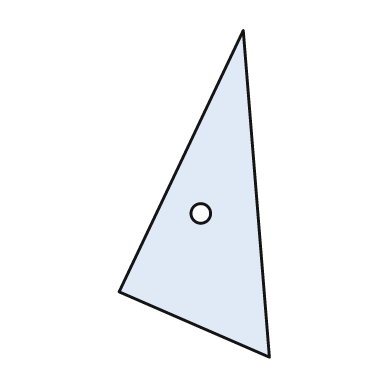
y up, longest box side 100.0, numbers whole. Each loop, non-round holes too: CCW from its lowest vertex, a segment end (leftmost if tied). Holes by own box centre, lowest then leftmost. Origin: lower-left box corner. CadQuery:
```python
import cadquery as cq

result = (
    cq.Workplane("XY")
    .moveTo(46.0, 0.0)
    .lineTo(38.0, 100.0)
    .lineTo(0.0, 20.0)
    .close()
    .moveTo(25.0, 44.0)
    .circle(3.0)
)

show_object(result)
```